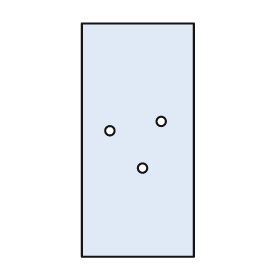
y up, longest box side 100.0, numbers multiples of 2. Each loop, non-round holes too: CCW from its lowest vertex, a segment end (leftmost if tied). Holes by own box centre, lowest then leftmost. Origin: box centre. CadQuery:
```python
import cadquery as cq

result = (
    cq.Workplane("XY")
    .moveTo(-24.0, -50.0)
    .lineTo(24.0, -50.0)
    .lineTo(24.0, 50.0)
    .lineTo(-24.0, 50.0)
    .close()
    .moveTo(2.0, -12.0)
    .circle(2.0)
    .moveTo(-12.0, 4.0)
    .circle(2.0)
    .moveTo(10.0, 8.0)
    .circle(2.0)
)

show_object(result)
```